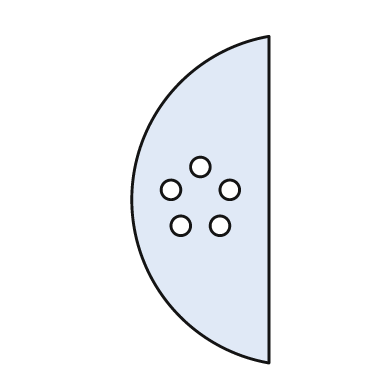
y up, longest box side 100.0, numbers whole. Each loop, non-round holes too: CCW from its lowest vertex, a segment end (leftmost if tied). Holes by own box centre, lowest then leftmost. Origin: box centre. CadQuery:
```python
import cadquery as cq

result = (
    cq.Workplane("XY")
    .moveTo(21.0, -50.0)
    .lineTo(21.0, 50.0)
    .threePointArc((-21.0, 0.0), (21.0, -50.0))
    .close()
    .moveTo(-6.0, -8.0)
    .circle(3.0)
    .moveTo(6.0, -8.0)
    .circle(3.0)
    .moveTo(-9.0, 3.0)
    .circle(3.0)
    .moveTo(9.0, 3.0)
    .circle(3.0)
    .moveTo(0.0, 10.0)
    .circle(3.0)
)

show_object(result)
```